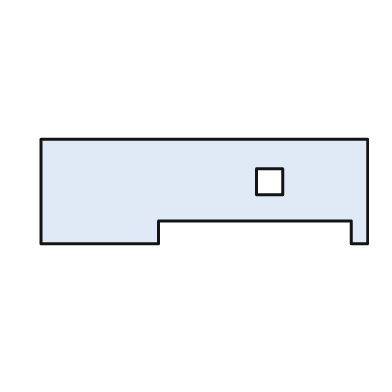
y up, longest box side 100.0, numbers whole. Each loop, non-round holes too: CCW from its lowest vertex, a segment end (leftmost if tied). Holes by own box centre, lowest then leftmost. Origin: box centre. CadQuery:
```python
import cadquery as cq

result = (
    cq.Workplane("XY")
    .moveTo(-50.0, -16.0)
    .lineTo(-14.0, -16.0)
    .lineTo(-14.0, -9.0)
    .lineTo(45.0, -9.0)
    .lineTo(45.0, -16.0)
    .lineTo(50.0, -16.0)
    .lineTo(50.0, 16.0)
    .lineTo(-50.0, 16.0)
    .close()
    .moveTo(16.0, -1.0)
    .lineTo(24.0, -1.0)
    .lineTo(24.0, 7.0)
    .lineTo(16.0, 7.0)
    .close()
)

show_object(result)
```